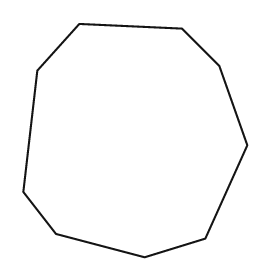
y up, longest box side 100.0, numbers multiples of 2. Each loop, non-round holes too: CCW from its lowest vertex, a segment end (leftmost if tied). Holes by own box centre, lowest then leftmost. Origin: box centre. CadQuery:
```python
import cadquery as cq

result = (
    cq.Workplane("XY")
    .moveTo(4.0, -50.0)
    .lineTo(30.0, -42.0)
    .lineTo(48.0, -2.0)
    .lineTo(36.0, 32.0)
    .lineTo(20.0, 48.0)
    .lineTo(-24.0, 50.0)
    .lineTo(-42.0, 30.0)
    .lineTo(-48.0, -22.0)
    .lineTo(-34.0, -40.0)
    .close()
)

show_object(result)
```